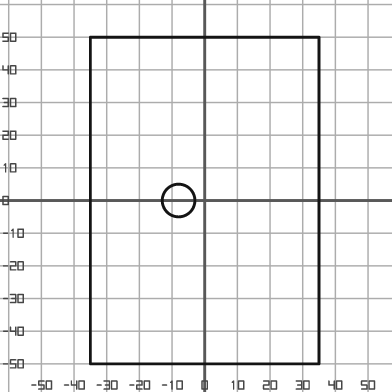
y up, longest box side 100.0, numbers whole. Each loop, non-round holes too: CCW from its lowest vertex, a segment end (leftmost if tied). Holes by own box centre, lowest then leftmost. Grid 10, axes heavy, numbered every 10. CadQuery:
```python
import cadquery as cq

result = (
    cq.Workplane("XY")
    .moveTo(-35.0, -50.0)
    .lineTo(35.0, -50.0)
    .lineTo(35.0, 50.0)
    .lineTo(-35.0, 50.0)
    .close()
    .moveTo(-8.0, 0.0)
    .circle(5.0)
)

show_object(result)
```